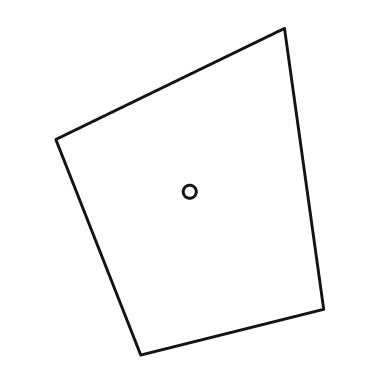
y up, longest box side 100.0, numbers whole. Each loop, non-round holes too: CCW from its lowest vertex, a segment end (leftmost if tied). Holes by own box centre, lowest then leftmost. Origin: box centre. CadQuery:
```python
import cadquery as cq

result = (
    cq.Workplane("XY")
    .moveTo(-15.0, -50.0)
    .lineTo(41.0, -36.0)
    .lineTo(29.0, 50.0)
    .lineTo(-41.0, 16.0)
    .close()
    .moveTo(0.0, 0.0)
    .circle(2.0)
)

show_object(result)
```